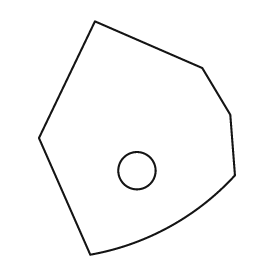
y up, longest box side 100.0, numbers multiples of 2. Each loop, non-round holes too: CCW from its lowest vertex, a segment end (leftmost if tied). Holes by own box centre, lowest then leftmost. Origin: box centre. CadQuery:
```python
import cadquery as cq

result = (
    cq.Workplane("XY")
    .moveTo(-20.0, -50.0)
    .threePointArc((14.0, -38.0), (42.0, -16.0))
    .lineTo(40.0, 10.0)
    .lineTo(28.0, 30.0)
    .lineTo(-18.0, 50.0)
    .lineTo(-42.0, 0.0)
    .close()
    .moveTo(0.0, -14.0)
    .circle(8.0)
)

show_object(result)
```